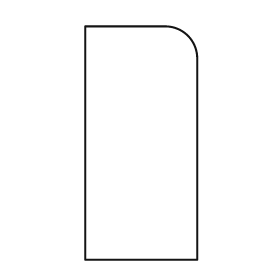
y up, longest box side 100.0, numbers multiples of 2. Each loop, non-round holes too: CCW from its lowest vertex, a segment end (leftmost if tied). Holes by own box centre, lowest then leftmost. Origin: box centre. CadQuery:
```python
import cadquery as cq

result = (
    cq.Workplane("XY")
    .moveTo(-24.0, -50.0)
    .lineTo(24.0, -50.0)
    .lineTo(24.0, 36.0)
    .threePointArc((20.0, 46.0), (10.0, 50.0))
    .lineTo(-24.0, 50.0)
    .close()
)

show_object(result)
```